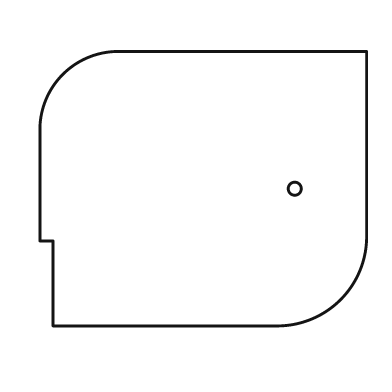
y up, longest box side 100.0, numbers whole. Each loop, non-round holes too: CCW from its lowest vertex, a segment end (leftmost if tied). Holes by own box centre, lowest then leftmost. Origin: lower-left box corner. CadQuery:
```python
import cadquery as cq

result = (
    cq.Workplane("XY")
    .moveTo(4.0, 0.0)
    .lineTo(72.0, 0.0)
    .threePointArc((92.0, 8.0), (100.0, 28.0))
    .lineTo(100.0, 84.0)
    .lineTo(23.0, 84.0)
    .threePointArc((7.0, 77.0), (0.0, 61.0))
    .lineTo(0.0, 26.0)
    .lineTo(4.0, 26.0)
    .close()
    .moveTo(78.0, 42.0)
    .circle(2.0)
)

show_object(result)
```